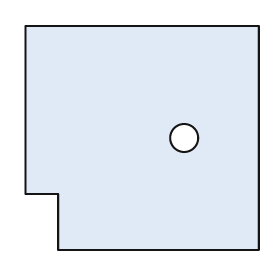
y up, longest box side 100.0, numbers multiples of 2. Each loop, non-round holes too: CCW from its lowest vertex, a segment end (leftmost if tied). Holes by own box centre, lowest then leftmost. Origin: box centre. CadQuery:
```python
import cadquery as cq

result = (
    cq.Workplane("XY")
    .moveTo(-36.0, -48.0)
    .lineTo(50.0, -48.0)
    .lineTo(50.0, 48.0)
    .lineTo(-50.0, 48.0)
    .lineTo(-50.0, -24.0)
    .lineTo(-36.0, -24.0)
    .close()
    .moveTo(18.0, 0.0)
    .circle(6.0)
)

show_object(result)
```